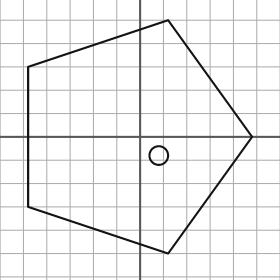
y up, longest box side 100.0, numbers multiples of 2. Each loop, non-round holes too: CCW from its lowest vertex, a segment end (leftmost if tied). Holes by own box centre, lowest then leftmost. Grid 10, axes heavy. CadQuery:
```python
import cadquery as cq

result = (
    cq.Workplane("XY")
    .moveTo(12.0, -50.0)
    .lineTo(48.0, 0.0)
    .lineTo(12.0, 50.0)
    .lineTo(-48.0, 30.0)
    .lineTo(-48.0, -30.0)
    .close()
    .moveTo(8.0, -8.0)
    .circle(4.0)
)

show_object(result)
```